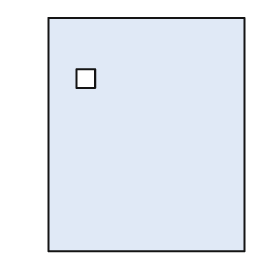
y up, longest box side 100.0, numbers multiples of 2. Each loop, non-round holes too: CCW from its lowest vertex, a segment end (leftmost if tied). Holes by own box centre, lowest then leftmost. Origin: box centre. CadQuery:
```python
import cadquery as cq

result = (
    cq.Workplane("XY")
    .moveTo(-42.0, -50.0)
    .lineTo(42.0, -50.0)
    .lineTo(42.0, 50.0)
    .lineTo(-42.0, 50.0)
    .close()
    .moveTo(-30.0, 20.0)
    .lineTo(-22.0, 20.0)
    .lineTo(-22.0, 28.0)
    .lineTo(-30.0, 28.0)
    .close()
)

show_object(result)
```